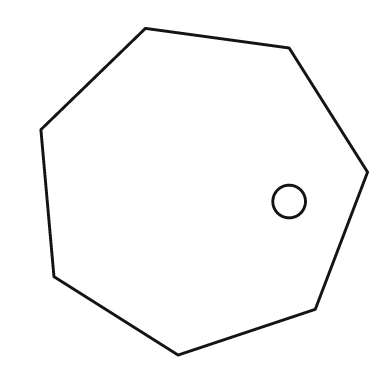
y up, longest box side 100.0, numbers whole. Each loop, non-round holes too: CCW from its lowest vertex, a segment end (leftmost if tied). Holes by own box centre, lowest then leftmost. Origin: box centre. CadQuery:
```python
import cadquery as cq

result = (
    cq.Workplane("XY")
    .moveTo(-8.0, -50.0)
    .lineTo(34.0, -36.0)
    .lineTo(50.0, 6.0)
    .lineTo(26.0, 44.0)
    .lineTo(-18.0, 50.0)
    .lineTo(-50.0, 19.0)
    .lineTo(-46.0, -26.0)
    .close()
    .moveTo(26.0, -3.0)
    .circle(5.0)
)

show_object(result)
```